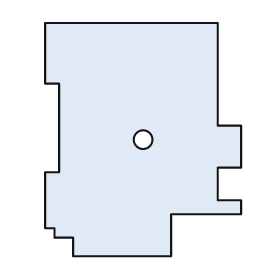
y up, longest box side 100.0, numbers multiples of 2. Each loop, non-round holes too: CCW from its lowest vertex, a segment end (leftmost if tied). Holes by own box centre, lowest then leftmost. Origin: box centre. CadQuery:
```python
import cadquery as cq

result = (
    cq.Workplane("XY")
    .moveTo(-30.0, -50.0)
    .lineTo(12.0, -50.0)
    .lineTo(12.0, -32.0)
    .lineTo(42.0, -32.0)
    .lineTo(42.0, -26.0)
    .lineTo(32.0, -26.0)
    .lineTo(32.0, -12.0)
    .lineTo(42.0, -12.0)
    .lineTo(42.0, 6.0)
    .lineTo(32.0, 6.0)
    .lineTo(32.0, 50.0)
    .lineTo(-42.0, 50.0)
    .lineTo(-42.0, 24.0)
    .lineTo(-36.0, 24.0)
    .lineTo(-36.0, -14.0)
    .lineTo(-42.0, -14.0)
    .lineTo(-42.0, -38.0)
    .lineTo(-38.0, -38.0)
    .lineTo(-38.0, -42.0)
    .lineTo(-30.0, -42.0)
    .close()
    .moveTo(0.0, 0.0)
    .circle(4.0)
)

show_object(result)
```